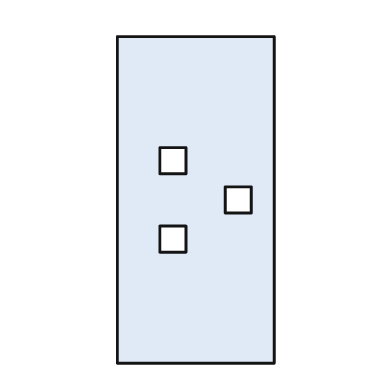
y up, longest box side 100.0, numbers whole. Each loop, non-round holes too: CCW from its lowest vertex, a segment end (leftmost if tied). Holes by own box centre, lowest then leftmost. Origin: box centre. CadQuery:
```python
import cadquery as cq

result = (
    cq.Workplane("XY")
    .moveTo(-24.0, -50.0)
    .lineTo(24.0, -50.0)
    .lineTo(24.0, 50.0)
    .lineTo(-24.0, 50.0)
    .close()
    .moveTo(-11.0, -16.0)
    .lineTo(-3.0, -16.0)
    .lineTo(-3.0, -8.0)
    .lineTo(-11.0, -8.0)
    .close()
    .moveTo(9.0, -4.0)
    .lineTo(17.0, -4.0)
    .lineTo(17.0, 4.0)
    .lineTo(9.0, 4.0)
    .close()
    .moveTo(-11.0, 8.0)
    .lineTo(-3.0, 8.0)
    .lineTo(-3.0, 16.0)
    .lineTo(-11.0, 16.0)
    .close()
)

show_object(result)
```